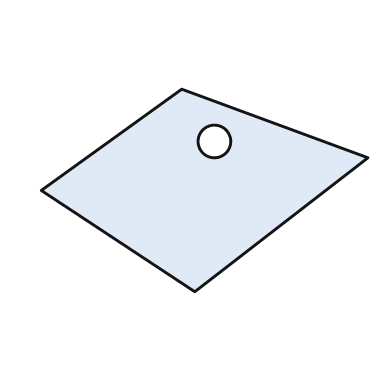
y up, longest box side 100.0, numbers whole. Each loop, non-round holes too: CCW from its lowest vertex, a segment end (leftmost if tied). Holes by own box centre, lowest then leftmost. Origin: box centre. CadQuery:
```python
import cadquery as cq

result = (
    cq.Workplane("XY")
    .moveTo(-3.0, -31.0)
    .lineTo(50.0, 10.0)
    .lineTo(-7.0, 31.0)
    .lineTo(-50.0, 0.0)
    .close()
    .moveTo(3.0, 15.0)
    .circle(5.0)
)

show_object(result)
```